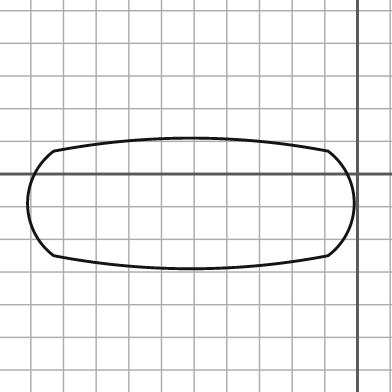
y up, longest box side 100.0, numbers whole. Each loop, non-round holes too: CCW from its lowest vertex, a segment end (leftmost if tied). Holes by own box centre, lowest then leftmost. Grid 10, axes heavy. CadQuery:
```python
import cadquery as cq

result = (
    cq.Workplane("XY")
    .moveTo(-93.0, -25.0)
    .threePointArc((-51.0, -29.0), (-9.0, -25.0))
    .threePointArc((-1.0, -9.0), (-9.0, 7.0))
    .threePointArc((-51.0, 11.0), (-93.0, 7.0))
    .threePointArc((-101.0, -9.0), (-93.0, -25.0))
    .close()
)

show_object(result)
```